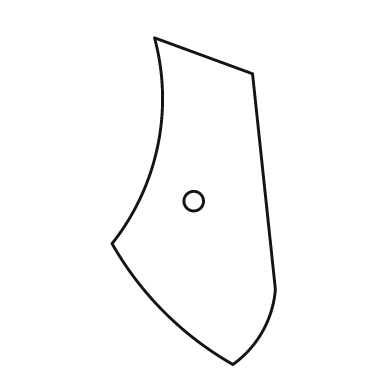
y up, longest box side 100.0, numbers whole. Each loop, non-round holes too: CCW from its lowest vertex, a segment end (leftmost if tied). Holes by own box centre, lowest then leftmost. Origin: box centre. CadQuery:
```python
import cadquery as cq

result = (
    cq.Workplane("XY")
    .moveTo(12.0, -50.0)
    .threePointArc((21.0, -40.0), (25.0, -27.0))
    .lineTo(18.0, 39.0)
    .lineTo(-12.0, 50.0)
    .threePointArc((-11.0, 17.0), (-25.0, -13.0))
    .threePointArc((-9.0, -34.0), (12.0, -50.0))
    .close()
    .moveTo(0.0, 0.0)
    .circle(3.0)
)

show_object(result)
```